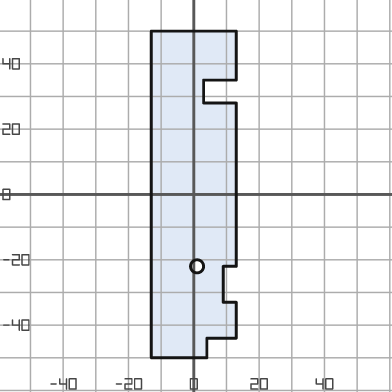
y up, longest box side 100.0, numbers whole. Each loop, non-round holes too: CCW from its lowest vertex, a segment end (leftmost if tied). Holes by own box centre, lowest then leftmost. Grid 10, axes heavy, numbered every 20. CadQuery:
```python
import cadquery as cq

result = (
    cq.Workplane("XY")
    .moveTo(-13.0, -50.0)
    .lineTo(4.0, -50.0)
    .lineTo(4.0, -44.0)
    .lineTo(13.0, -44.0)
    .lineTo(13.0, -33.0)
    .lineTo(9.0, -33.0)
    .lineTo(9.0, -22.0)
    .lineTo(13.0, -22.0)
    .lineTo(13.0, 28.0)
    .lineTo(3.0, 28.0)
    .lineTo(3.0, 35.0)
    .lineTo(13.0, 35.0)
    .lineTo(13.0, 50.0)
    .lineTo(-13.0, 50.0)
    .close()
    .moveTo(1.0, -22.0)
    .circle(2.0)
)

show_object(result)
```